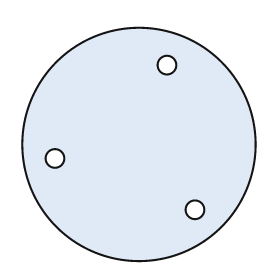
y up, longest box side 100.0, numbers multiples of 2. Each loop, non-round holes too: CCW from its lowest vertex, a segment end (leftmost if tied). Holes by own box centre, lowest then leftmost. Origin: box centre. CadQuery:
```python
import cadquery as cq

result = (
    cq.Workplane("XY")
    .moveTo(0.0, 0.0)
    .circle(50.0)
    .moveTo(24.0, -28.0)
    .circle(4.0)
    .moveTo(-36.0, -6.0)
    .circle(4.0)
    .moveTo(12.0, 34.0)
    .circle(4.0)
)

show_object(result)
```